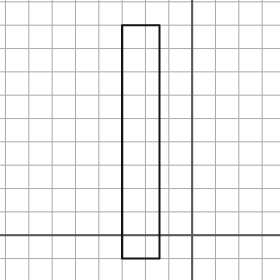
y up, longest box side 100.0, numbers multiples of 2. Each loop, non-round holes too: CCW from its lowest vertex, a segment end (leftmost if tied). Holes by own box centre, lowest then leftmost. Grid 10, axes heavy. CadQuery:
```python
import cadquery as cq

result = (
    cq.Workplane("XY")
    .moveTo(-30.0, -10.0)
    .lineTo(-14.0, -10.0)
    .lineTo(-14.0, 90.0)
    .lineTo(-30.0, 90.0)
    .close()
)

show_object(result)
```